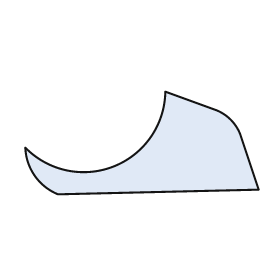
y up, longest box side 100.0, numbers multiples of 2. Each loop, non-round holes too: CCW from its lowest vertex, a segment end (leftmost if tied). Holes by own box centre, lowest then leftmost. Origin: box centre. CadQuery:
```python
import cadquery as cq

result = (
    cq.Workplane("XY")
    .moveTo(-36.0, -22.0)
    .lineTo(50.0, -20.0)
    .lineTo(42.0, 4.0)
    .threePointArc((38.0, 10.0), (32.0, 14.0))
    .lineTo(10.0, 22.0)
    .threePointArc((-12.0, -10.0), (-50.0, -2.0))
    .threePointArc((-46.0, -14.0), (-36.0, -22.0))
    .close()
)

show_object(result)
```